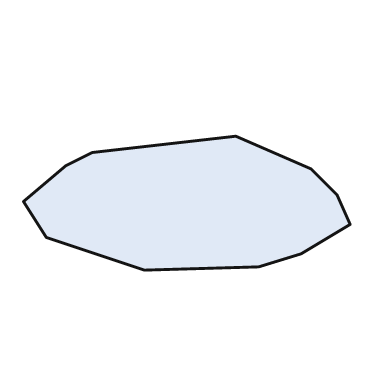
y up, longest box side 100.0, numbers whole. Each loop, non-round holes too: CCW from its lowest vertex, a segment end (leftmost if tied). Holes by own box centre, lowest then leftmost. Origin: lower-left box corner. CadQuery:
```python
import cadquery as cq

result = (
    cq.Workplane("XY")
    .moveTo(37.0, 0.0)
    .lineTo(72.0, 1.0)
    .lineTo(85.0, 5.0)
    .lineTo(100.0, 14.0)
    .lineTo(96.0, 23.0)
    .lineTo(88.0, 31.0)
    .lineTo(65.0, 41.0)
    .lineTo(21.0, 36.0)
    .lineTo(13.0, 32.0)
    .lineTo(0.0, 21.0)
    .lineTo(7.0, 10.0)
    .close()
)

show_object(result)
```